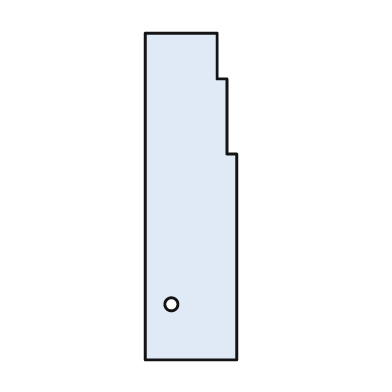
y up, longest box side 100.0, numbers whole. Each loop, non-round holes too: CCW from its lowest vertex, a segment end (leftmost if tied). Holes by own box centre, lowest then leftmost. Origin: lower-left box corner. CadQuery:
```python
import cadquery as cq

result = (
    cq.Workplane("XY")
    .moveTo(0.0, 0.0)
    .lineTo(28.0, 0.0)
    .lineTo(28.0, 63.0)
    .lineTo(25.0, 63.0)
    .lineTo(25.0, 86.0)
    .lineTo(22.0, 86.0)
    .lineTo(22.0, 100.0)
    .lineTo(0.0, 100.0)
    .close()
    .moveTo(8.0, 17.0)
    .circle(2.0)
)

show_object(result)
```